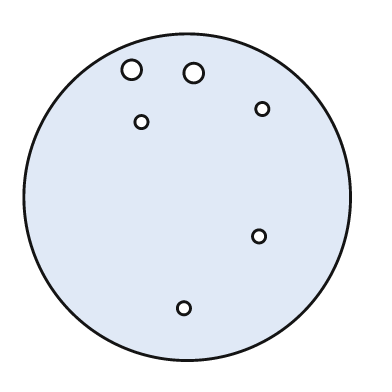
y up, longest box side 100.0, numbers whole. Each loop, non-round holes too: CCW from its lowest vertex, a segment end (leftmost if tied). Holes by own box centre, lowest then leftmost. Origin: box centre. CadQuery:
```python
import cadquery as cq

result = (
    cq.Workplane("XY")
    .moveTo(0.0, 0.0)
    .circle(50.0)
    .moveTo(-1.0, -34.0)
    .circle(2.0)
    .moveTo(22.0, -12.0)
    .circle(2.0)
    .moveTo(-14.0, 23.0)
    .circle(2.0)
    .moveTo(23.0, 27.0)
    .circle(2.0)
    .moveTo(2.0, 38.0)
    .circle(3.0)
    .moveTo(-17.0, 39.0)
    .circle(3.0)
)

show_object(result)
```